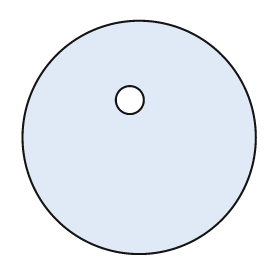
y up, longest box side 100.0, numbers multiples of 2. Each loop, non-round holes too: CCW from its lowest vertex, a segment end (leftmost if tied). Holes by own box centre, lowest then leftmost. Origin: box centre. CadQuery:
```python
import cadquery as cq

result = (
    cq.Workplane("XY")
    .moveTo(0.0, 0.0)
    .circle(50.0)
    .moveTo(-4.0, 16.0)
    .circle(6.0)
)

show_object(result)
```